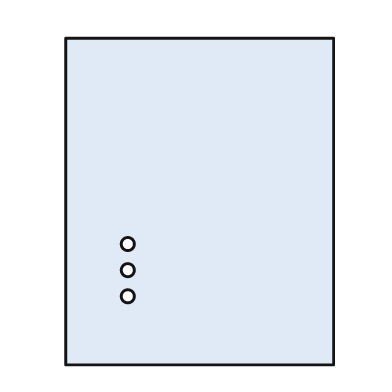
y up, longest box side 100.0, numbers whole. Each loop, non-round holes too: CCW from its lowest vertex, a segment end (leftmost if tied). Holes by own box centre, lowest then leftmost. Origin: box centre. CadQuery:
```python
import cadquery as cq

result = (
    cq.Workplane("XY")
    .moveTo(-41.0, -50.0)
    .lineTo(41.0, -50.0)
    .lineTo(41.0, 50.0)
    .lineTo(-41.0, 50.0)
    .close()
    .moveTo(-22.0, -29.0)
    .circle(2.0)
    .moveTo(-22.0, -21.0)
    .circle(2.0)
    .moveTo(-22.0, -13.0)
    .circle(2.0)
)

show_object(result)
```